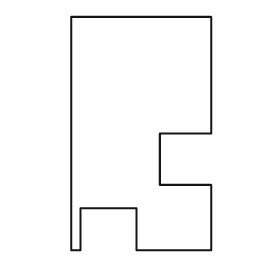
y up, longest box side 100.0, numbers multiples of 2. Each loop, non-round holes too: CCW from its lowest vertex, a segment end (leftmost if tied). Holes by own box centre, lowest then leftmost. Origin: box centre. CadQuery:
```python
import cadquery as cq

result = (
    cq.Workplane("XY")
    .moveTo(-30.0, -50.0)
    .lineTo(-26.0, -50.0)
    .lineTo(-26.0, -32.0)
    .lineTo(-2.0, -32.0)
    .lineTo(-2.0, -50.0)
    .lineTo(30.0, -50.0)
    .lineTo(30.0, -22.0)
    .lineTo(8.0, -22.0)
    .lineTo(8.0, 0.0)
    .lineTo(30.0, 0.0)
    .lineTo(30.0, 50.0)
    .lineTo(-30.0, 50.0)
    .close()
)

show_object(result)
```